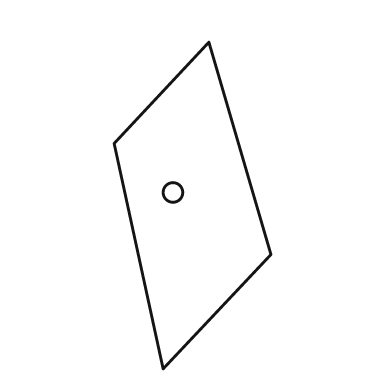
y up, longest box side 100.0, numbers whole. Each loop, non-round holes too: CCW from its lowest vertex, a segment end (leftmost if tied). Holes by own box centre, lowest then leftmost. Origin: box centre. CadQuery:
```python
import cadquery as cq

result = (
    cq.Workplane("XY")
    .moveTo(-9.0, -50.0)
    .lineTo(24.0, -15.0)
    .lineTo(5.0, 50.0)
    .lineTo(-24.0, 19.0)
    .close()
    .moveTo(-6.0, 4.0)
    .circle(3.0)
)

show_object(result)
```